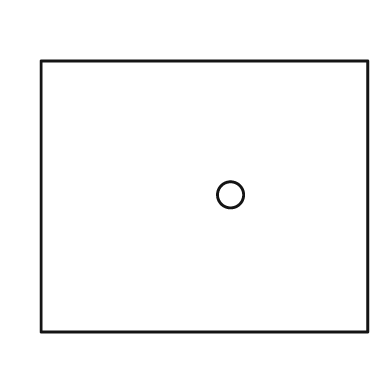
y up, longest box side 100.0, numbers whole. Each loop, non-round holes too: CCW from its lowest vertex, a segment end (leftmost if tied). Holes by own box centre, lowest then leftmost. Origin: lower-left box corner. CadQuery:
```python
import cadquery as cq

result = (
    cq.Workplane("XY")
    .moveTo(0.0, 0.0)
    .lineTo(100.0, 0.0)
    .lineTo(100.0, 83.0)
    .lineTo(0.0, 83.0)
    .close()
    .moveTo(58.0, 42.0)
    .circle(4.0)
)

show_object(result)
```